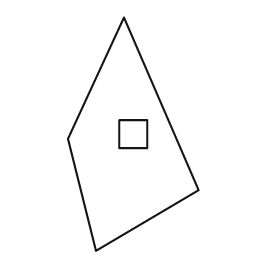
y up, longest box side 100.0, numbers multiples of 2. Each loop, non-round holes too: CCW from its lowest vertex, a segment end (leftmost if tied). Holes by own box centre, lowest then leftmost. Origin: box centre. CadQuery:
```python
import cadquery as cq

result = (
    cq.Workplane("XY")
    .moveTo(-16.0, -50.0)
    .lineTo(28.0, -24.0)
    .lineTo(-4.0, 50.0)
    .lineTo(-28.0, -2.0)
    .close()
    .moveTo(-6.0, -6.0)
    .lineTo(6.0, -6.0)
    .lineTo(6.0, 6.0)
    .lineTo(-6.0, 6.0)
    .close()
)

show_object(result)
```